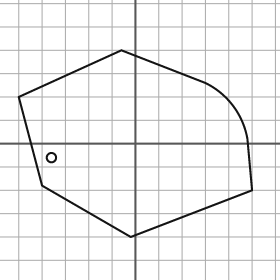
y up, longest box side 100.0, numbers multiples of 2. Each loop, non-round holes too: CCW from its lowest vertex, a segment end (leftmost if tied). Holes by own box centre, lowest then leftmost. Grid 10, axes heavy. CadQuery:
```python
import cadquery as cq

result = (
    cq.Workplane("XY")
    .moveTo(-2.0, -40.0)
    .lineTo(50.0, -20.0)
    .lineTo(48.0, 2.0)
    .threePointArc((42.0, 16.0), (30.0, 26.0))
    .lineTo(-6.0, 40.0)
    .lineTo(-50.0, 20.0)
    .lineTo(-40.0, -18.0)
    .close()
    .moveTo(-36.0, -6.0)
    .circle(2.0)
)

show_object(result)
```